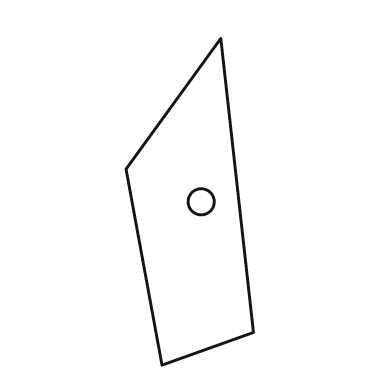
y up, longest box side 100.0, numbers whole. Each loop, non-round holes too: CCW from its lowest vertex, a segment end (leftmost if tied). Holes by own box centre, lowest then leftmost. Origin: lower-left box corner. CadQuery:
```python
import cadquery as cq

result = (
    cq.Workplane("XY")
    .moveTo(11.0, 0.0)
    .lineTo(39.0, 10.0)
    .lineTo(29.0, 100.0)
    .lineTo(0.0, 60.0)
    .close()
    .moveTo(23.0, 50.0)
    .circle(4.0)
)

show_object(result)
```